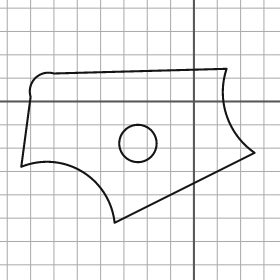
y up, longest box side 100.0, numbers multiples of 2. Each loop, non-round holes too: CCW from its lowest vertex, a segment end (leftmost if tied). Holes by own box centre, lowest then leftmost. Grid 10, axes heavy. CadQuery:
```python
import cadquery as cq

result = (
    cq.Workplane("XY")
    .moveTo(-34.0, -52.0)
    .lineTo(26.0, -22.0)
    .threePointArc((14.0, -6.0), (14.0, 14.0))
    .lineTo(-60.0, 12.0)
    .threePointArc((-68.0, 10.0), (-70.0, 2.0))
    .lineTo(-74.0, -28.0)
    .threePointArc((-48.0, -30.0), (-34.0, -52.0))
    .close()
    .moveTo(-24.0, -18.0)
    .circle(8.0)
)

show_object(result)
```